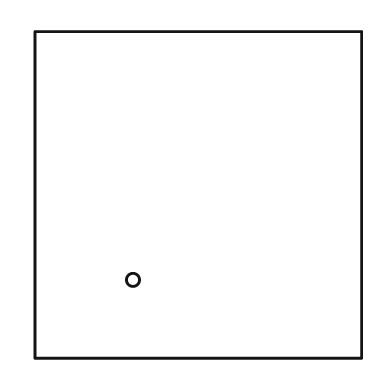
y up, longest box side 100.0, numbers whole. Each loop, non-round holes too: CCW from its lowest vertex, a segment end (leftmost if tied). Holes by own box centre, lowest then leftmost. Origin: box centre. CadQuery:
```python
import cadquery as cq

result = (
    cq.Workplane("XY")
    .moveTo(-50.0, -50.0)
    .lineTo(50.0, -50.0)
    .lineTo(50.0, 50.0)
    .lineTo(-50.0, 50.0)
    .close()
    .moveTo(-20.0, -26.0)
    .circle(2.0)
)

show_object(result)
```